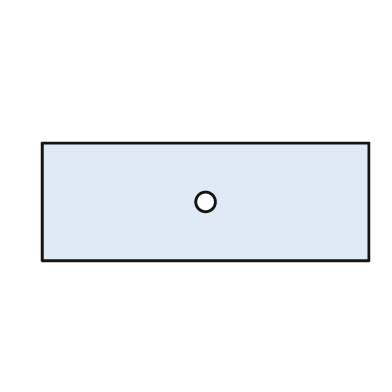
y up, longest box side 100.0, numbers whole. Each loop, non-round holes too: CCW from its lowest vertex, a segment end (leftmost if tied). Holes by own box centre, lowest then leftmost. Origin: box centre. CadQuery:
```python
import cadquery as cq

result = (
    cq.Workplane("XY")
    .moveTo(-50.0, -18.0)
    .lineTo(50.0, -18.0)
    .lineTo(50.0, 18.0)
    .lineTo(-50.0, 18.0)
    .close()
    .moveTo(0.0, 0.0)
    .circle(3.0)
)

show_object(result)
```